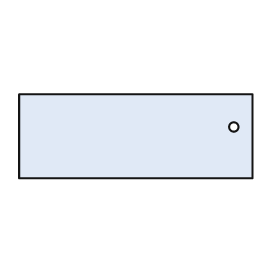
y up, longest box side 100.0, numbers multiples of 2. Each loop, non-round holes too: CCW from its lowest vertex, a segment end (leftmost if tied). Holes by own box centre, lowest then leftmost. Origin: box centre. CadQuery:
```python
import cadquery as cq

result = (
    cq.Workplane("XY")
    .moveTo(-50.0, -18.0)
    .lineTo(50.0, -18.0)
    .lineTo(50.0, 18.0)
    .lineTo(-50.0, 18.0)
    .close()
    .moveTo(42.0, 4.0)
    .circle(2.0)
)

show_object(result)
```